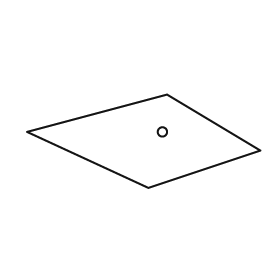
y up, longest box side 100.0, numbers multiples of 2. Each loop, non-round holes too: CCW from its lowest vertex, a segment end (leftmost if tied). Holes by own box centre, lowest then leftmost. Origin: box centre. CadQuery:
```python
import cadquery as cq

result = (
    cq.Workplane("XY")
    .moveTo(2.0, -20.0)
    .lineTo(50.0, -4.0)
    .lineTo(10.0, 20.0)
    .lineTo(-50.0, 4.0)
    .close()
    .moveTo(8.0, 4.0)
    .circle(2.0)
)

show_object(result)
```